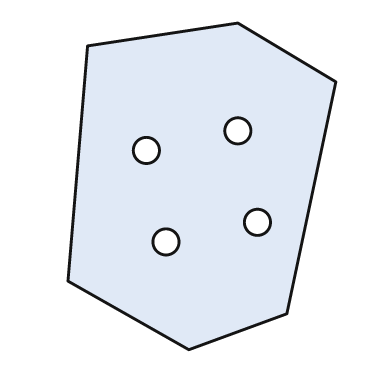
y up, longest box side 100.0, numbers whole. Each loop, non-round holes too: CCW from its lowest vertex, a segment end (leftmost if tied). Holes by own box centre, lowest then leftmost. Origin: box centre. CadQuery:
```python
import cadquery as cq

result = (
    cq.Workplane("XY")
    .moveTo(-4.0, -50.0)
    .lineTo(26.0, -39.0)
    .lineTo(41.0, 32.0)
    .lineTo(11.0, 50.0)
    .lineTo(-35.0, 43.0)
    .lineTo(-41.0, -29.0)
    .close()
    .moveTo(-11.0, -17.0)
    .circle(4.0)
    .moveTo(17.0, -11.0)
    .circle(4.0)
    .moveTo(-17.0, 11.0)
    .circle(4.0)
    .moveTo(11.0, 17.0)
    .circle(4.0)
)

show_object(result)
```